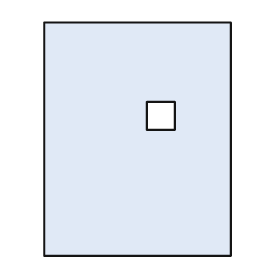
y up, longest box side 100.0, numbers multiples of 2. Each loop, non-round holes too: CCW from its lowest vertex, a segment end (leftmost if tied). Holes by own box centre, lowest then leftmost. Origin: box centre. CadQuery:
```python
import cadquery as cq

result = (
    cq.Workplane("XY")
    .moveTo(-40.0, -50.0)
    .lineTo(40.0, -50.0)
    .lineTo(40.0, 50.0)
    .lineTo(-40.0, 50.0)
    .close()
    .moveTo(4.0, 4.0)
    .lineTo(16.0, 4.0)
    .lineTo(16.0, 16.0)
    .lineTo(4.0, 16.0)
    .close()
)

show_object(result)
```